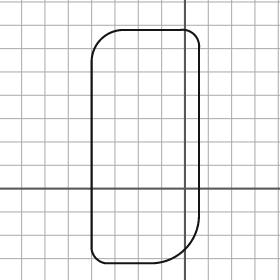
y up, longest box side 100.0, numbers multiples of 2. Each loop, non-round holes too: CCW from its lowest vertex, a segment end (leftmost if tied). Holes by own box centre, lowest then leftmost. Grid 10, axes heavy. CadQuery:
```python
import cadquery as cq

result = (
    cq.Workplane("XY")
    .moveTo(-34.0, -32.0)
    .lineTo(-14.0, -32.0)
    .threePointArc((0.0, -26.0), (6.0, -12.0))
    .lineTo(6.0, 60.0)
    .threePointArc((4.0, 66.0), (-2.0, 68.0))
    .lineTo(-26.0, 68.0)
    .threePointArc((-36.0, 64.0), (-40.0, 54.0))
    .lineTo(-40.0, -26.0)
    .threePointArc((-38.0, -30.0), (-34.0, -32.0))
    .close()
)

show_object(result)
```